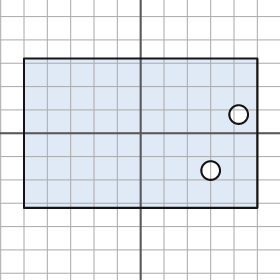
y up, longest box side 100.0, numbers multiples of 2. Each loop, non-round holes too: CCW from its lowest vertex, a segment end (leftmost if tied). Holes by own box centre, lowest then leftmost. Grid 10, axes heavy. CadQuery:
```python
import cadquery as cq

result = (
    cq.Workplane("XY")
    .moveTo(-50.0, -32.0)
    .lineTo(50.0, -32.0)
    .lineTo(50.0, 32.0)
    .lineTo(-50.0, 32.0)
    .close()
    .moveTo(30.0, -16.0)
    .circle(4.0)
    .moveTo(42.0, 8.0)
    .circle(4.0)
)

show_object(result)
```